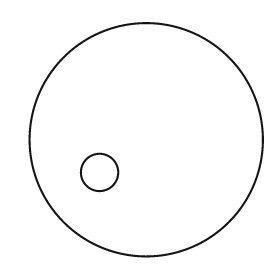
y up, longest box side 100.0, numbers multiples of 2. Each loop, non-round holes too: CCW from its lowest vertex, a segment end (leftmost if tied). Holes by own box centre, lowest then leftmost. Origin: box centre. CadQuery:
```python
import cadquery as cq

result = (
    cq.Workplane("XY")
    .moveTo(0.0, 0.0)
    .circle(50.0)
    .moveTo(-20.0, -14.0)
    .circle(8.0)
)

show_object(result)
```